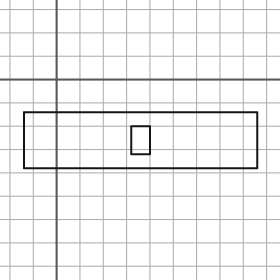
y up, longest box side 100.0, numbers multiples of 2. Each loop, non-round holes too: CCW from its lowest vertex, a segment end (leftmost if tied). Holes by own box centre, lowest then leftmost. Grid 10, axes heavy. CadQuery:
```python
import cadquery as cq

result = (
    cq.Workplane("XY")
    .moveTo(-14.0, -38.0)
    .lineTo(86.0, -38.0)
    .lineTo(86.0, -14.0)
    .lineTo(-14.0, -14.0)
    .close()
    .moveTo(32.0, -32.0)
    .lineTo(40.0, -32.0)
    .lineTo(40.0, -20.0)
    .lineTo(32.0, -20.0)
    .close()
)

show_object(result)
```